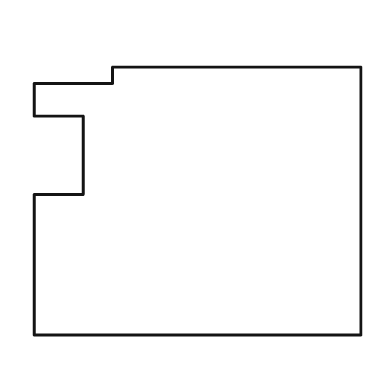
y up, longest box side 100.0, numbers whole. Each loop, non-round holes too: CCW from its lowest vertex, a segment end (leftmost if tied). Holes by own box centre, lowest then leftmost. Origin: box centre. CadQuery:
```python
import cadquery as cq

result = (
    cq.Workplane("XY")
    .moveTo(-50.0, -41.0)
    .lineTo(50.0, -41.0)
    .lineTo(50.0, 41.0)
    .lineTo(-26.0, 41.0)
    .lineTo(-26.0, 36.0)
    .lineTo(-50.0, 36.0)
    .lineTo(-50.0, 26.0)
    .lineTo(-35.0, 26.0)
    .lineTo(-35.0, 2.0)
    .lineTo(-50.0, 2.0)
    .close()
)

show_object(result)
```